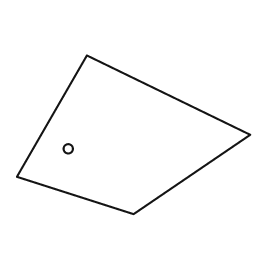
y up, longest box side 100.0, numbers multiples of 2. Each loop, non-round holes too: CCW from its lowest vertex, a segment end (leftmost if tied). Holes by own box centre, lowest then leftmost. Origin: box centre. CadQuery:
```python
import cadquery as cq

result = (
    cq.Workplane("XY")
    .moveTo(0.0, -34.0)
    .lineTo(50.0, 0.0)
    .lineTo(-20.0, 34.0)
    .lineTo(-50.0, -18.0)
    .close()
    .moveTo(-28.0, -6.0)
    .circle(2.0)
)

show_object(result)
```